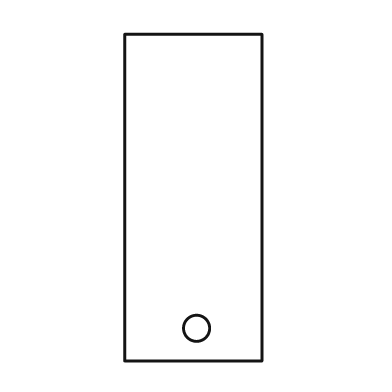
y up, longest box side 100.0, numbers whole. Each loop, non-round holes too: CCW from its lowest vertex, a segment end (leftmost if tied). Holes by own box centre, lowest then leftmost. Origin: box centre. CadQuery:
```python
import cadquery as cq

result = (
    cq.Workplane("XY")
    .moveTo(-21.0, -50.0)
    .lineTo(21.0, -50.0)
    .lineTo(21.0, 50.0)
    .lineTo(-21.0, 50.0)
    .close()
    .moveTo(1.0, -40.0)
    .circle(4.0)
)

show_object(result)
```